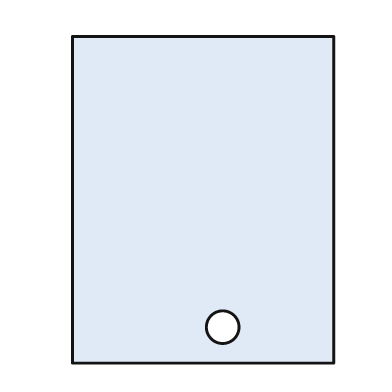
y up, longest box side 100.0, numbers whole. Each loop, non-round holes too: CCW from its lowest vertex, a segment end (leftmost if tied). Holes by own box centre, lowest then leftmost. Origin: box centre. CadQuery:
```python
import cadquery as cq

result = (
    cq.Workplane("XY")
    .moveTo(-40.0, -50.0)
    .lineTo(40.0, -50.0)
    .lineTo(40.0, 50.0)
    .lineTo(-40.0, 50.0)
    .close()
    .moveTo(6.0, -39.0)
    .circle(5.0)
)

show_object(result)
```